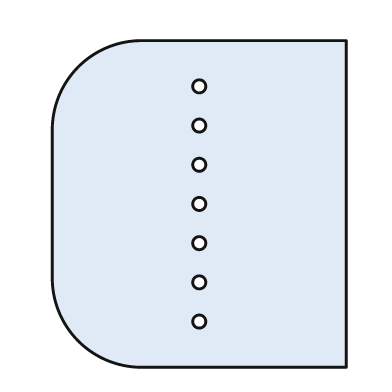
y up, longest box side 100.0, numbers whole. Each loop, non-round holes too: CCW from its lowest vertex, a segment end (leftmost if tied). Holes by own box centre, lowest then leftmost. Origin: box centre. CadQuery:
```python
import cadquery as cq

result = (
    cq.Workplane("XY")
    .moveTo(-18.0, -50.0)
    .lineTo(45.0, -50.0)
    .lineTo(45.0, 50.0)
    .lineTo(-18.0, 50.0)
    .threePointArc((-37.0, 42.0), (-45.0, 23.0))
    .lineTo(-45.0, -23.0)
    .threePointArc((-37.0, -42.0), (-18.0, -50.0))
    .close()
    .moveTo(0.0, -36.0)
    .circle(2.0)
    .moveTo(0.0, -24.0)
    .circle(2.0)
    .moveTo(0.0, -12.0)
    .circle(2.0)
    .moveTo(0.0, 0.0)
    .circle(2.0)
    .moveTo(0.0, 12.0)
    .circle(2.0)
    .moveTo(0.0, 24.0)
    .circle(2.0)
    .moveTo(0.0, 36.0)
    .circle(2.0)
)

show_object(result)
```